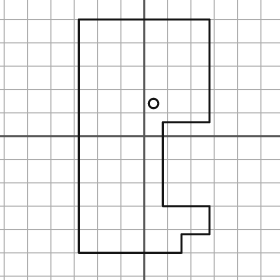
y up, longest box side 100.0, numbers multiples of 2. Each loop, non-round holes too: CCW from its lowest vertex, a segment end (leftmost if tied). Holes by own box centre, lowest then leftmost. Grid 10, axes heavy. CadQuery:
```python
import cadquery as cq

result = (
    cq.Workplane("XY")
    .moveTo(-28.0, -50.0)
    .lineTo(16.0, -50.0)
    .lineTo(16.0, -42.0)
    .lineTo(28.0, -42.0)
    .lineTo(28.0, -30.0)
    .lineTo(8.0, -30.0)
    .lineTo(8.0, 6.0)
    .lineTo(28.0, 6.0)
    .lineTo(28.0, 50.0)
    .lineTo(-28.0, 50.0)
    .close()
    .moveTo(4.0, 14.0)
    .circle(2.0)
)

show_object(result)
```